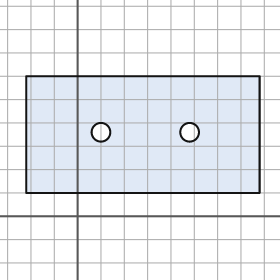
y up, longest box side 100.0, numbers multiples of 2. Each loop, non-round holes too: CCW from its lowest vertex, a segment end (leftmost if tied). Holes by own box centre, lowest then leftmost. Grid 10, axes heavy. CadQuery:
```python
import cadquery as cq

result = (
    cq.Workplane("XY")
    .moveTo(-22.0, 10.0)
    .lineTo(78.0, 10.0)
    .lineTo(78.0, 60.0)
    .lineTo(-22.0, 60.0)
    .close()
    .moveTo(10.0, 36.0)
    .circle(4.0)
    .moveTo(48.0, 36.0)
    .circle(4.0)
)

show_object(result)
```